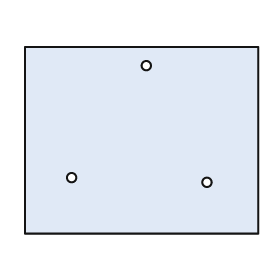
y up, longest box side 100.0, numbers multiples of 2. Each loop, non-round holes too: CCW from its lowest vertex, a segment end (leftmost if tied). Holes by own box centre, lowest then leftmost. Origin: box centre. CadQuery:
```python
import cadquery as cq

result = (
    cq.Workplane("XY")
    .moveTo(-50.0, -40.0)
    .lineTo(50.0, -40.0)
    .lineTo(50.0, 40.0)
    .lineTo(-50.0, 40.0)
    .close()
    .moveTo(28.0, -18.0)
    .circle(2.0)
    .moveTo(-30.0, -16.0)
    .circle(2.0)
    .moveTo(2.0, 32.0)
    .circle(2.0)
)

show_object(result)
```